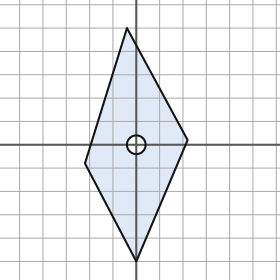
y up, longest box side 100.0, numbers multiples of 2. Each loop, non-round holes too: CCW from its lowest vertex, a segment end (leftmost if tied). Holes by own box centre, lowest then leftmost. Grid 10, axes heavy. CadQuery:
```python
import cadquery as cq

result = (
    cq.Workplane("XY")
    .moveTo(0.0, -50.0)
    .lineTo(22.0, 2.0)
    .lineTo(-4.0, 50.0)
    .lineTo(-22.0, -8.0)
    .close()
    .moveTo(0.0, 0.0)
    .circle(4.0)
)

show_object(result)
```